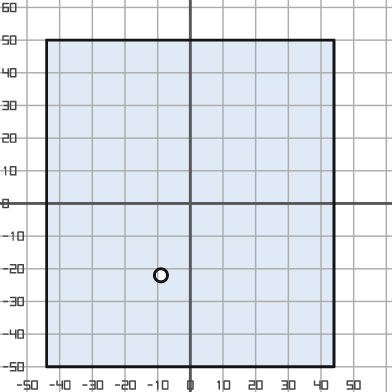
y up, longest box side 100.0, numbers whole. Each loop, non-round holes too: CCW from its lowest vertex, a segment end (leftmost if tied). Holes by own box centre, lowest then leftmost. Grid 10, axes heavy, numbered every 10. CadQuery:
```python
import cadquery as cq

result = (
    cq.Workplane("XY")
    .moveTo(-44.0, -50.0)
    .lineTo(44.0, -50.0)
    .lineTo(44.0, 50.0)
    .lineTo(-44.0, 50.0)
    .close()
    .moveTo(-9.0, -22.0)
    .circle(2.0)
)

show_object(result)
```